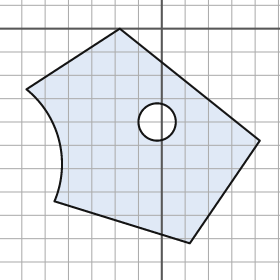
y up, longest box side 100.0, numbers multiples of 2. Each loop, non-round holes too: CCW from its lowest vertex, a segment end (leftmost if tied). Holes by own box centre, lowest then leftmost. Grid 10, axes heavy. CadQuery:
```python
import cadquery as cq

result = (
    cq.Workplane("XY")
    .moveTo(12.0, -92.0)
    .lineTo(42.0, -48.0)
    .lineTo(-18.0, 0.0)
    .lineTo(-58.0, -26.0)
    .threePointArc((-44.0, -48.0), (-46.0, -74.0))
    .close()
    .moveTo(-2.0, -40.0)
    .circle(8.0)
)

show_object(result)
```